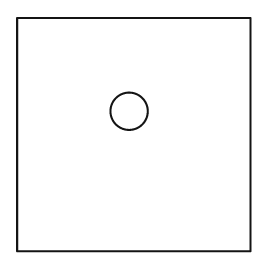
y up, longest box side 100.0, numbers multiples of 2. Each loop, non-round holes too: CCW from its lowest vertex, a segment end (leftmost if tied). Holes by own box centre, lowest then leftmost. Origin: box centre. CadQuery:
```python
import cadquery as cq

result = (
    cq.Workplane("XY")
    .moveTo(-50.0, -50.0)
    .lineTo(50.0, -50.0)
    .lineTo(50.0, 50.0)
    .lineTo(-50.0, 50.0)
    .close()
    .moveTo(-2.0, 10.0)
    .circle(8.0)
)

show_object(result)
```